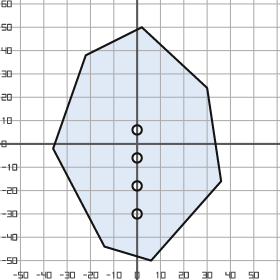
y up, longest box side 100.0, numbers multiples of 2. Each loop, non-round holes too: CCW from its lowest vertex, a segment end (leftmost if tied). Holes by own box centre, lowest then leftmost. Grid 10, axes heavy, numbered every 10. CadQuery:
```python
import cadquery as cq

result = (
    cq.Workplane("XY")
    .moveTo(6.0, -50.0)
    .lineTo(36.0, -16.0)
    .lineTo(30.0, 24.0)
    .lineTo(2.0, 50.0)
    .lineTo(-22.0, 38.0)
    .lineTo(-36.0, -2.0)
    .lineTo(-14.0, -44.0)
    .close()
    .moveTo(0.0, -30.0)
    .circle(2.0)
    .moveTo(0.0, -18.0)
    .circle(2.0)
    .moveTo(0.0, -6.0)
    .circle(2.0)
    .moveTo(0.0, 6.0)
    .circle(2.0)
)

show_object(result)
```